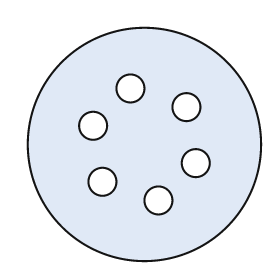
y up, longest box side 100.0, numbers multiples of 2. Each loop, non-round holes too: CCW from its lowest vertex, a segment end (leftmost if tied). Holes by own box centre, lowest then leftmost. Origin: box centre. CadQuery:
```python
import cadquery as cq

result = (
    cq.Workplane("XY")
    .moveTo(0.0, 0.0)
    .circle(50.0)
    .moveTo(6.0, -24.0)
    .circle(6.0)
    .moveTo(-18.0, -16.0)
    .circle(6.0)
    .moveTo(22.0, -8.0)
    .circle(6.0)
    .moveTo(-22.0, 8.0)
    .circle(6.0)
    .moveTo(18.0, 16.0)
    .circle(6.0)
    .moveTo(-6.0, 24.0)
    .circle(6.0)
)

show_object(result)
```